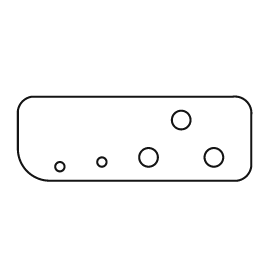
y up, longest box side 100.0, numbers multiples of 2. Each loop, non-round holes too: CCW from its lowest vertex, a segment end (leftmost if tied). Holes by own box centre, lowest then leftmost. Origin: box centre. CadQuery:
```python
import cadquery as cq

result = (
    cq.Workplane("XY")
    .moveTo(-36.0, -18.0)
    .lineTo(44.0, -18.0)
    .threePointArc((48.0, -16.0), (50.0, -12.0))
    .lineTo(50.0, 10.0)
    .threePointArc((48.0, 16.0), (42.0, 18.0))
    .lineTo(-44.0, 18.0)
    .threePointArc((-48.0, 16.0), (-50.0, 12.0))
    .lineTo(-50.0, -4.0)
    .threePointArc((-46.0, -14.0), (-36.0, -18.0))
    .close()
    .moveTo(-32.0, -12.0)
    .circle(2.0)
    .moveTo(-14.0, -10.0)
    .circle(2.0)
    .moveTo(6.0, -8.0)
    .circle(4.0)
    .moveTo(34.0, -8.0)
    .circle(4.0)
    .moveTo(20.0, 8.0)
    .circle(4.0)
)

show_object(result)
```